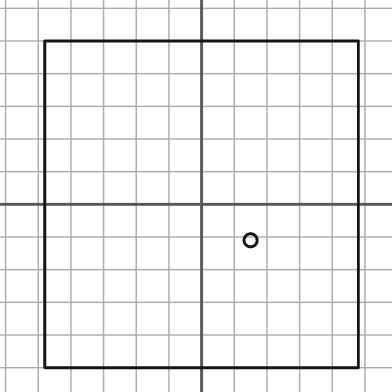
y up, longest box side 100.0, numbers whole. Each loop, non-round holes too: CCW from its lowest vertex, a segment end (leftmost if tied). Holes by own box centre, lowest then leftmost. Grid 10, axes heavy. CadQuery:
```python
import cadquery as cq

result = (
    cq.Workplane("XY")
    .moveTo(-48.0, -50.0)
    .lineTo(48.0, -50.0)
    .lineTo(48.0, 50.0)
    .lineTo(-48.0, 50.0)
    .close()
    .moveTo(15.0, -11.0)
    .circle(2.0)
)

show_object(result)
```